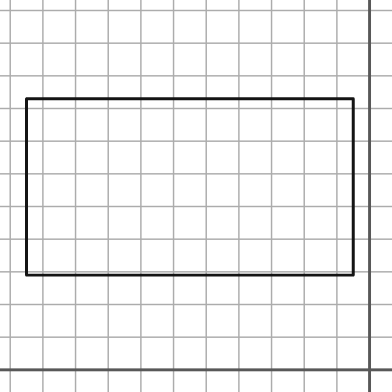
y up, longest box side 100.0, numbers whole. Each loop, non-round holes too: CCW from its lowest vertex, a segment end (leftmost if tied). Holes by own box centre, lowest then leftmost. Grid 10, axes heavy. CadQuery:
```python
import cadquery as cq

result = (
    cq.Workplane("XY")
    .moveTo(-105.0, 29.0)
    .lineTo(-5.0, 29.0)
    .lineTo(-5.0, 83.0)
    .lineTo(-105.0, 83.0)
    .close()
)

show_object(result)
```